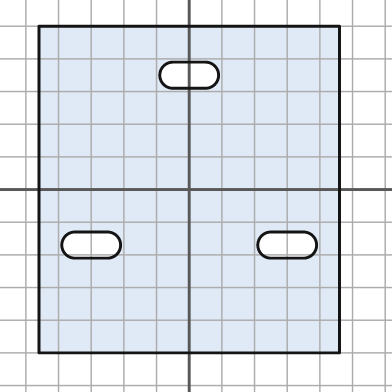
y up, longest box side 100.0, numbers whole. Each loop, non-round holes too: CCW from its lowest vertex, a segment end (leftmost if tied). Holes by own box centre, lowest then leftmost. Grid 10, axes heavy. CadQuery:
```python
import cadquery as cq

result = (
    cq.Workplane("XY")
    .moveTo(-46.0, -50.0)
    .lineTo(46.0, -50.0)
    .lineTo(46.0, 50.0)
    .lineTo(-46.0, 50.0)
    .close()
    .moveTo(-35.0, -21.0)
    .lineTo(-25.0, -21.0)
    .threePointArc((-21.0, -17.0), (-25.0, -13.0))
    .lineTo(-35.0, -13.0)
    .threePointArc((-39.0, -17.0), (-35.0, -21.0))
    .close()
    .moveTo(25.0, -21.0)
    .lineTo(35.0, -21.0)
    .threePointArc((39.0, -17.0), (35.0, -13.0))
    .lineTo(25.0, -13.0)
    .threePointArc((21.0, -17.0), (25.0, -21.0))
    .close()
    .moveTo(-5.0, 31.0)
    .lineTo(5.0, 31.0)
    .threePointArc((9.0, 35.0), (5.0, 39.0))
    .lineTo(-5.0, 39.0)
    .threePointArc((-9.0, 35.0), (-5.0, 31.0))
    .close()
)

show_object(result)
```